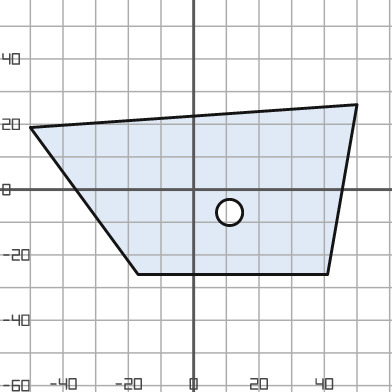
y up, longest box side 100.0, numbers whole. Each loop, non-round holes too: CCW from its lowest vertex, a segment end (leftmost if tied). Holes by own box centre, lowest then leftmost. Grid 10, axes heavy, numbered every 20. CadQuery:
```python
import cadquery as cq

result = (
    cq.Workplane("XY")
    .moveTo(-17.0, -26.0)
    .lineTo(41.0, -26.0)
    .lineTo(50.0, 26.0)
    .lineTo(-50.0, 19.0)
    .close()
    .moveTo(11.0, -7.0)
    .circle(4.0)
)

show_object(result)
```